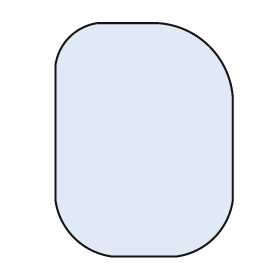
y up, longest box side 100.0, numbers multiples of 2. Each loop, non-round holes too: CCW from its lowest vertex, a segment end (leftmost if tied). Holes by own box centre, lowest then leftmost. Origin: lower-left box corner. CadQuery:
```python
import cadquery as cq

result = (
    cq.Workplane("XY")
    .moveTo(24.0, 0.0)
    .lineTo(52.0, 0.0)
    .threePointArc((68.0, 8.0), (76.0, 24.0))
    .lineTo(76.0, 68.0)
    .threePointArc((66.0, 90.0), (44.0, 100.0))
    .lineTo(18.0, 100.0)
    .threePointArc((6.0, 94.0), (0.0, 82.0))
    .lineTo(0.0, 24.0)
    .threePointArc((8.0, 8.0), (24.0, 0.0))
    .close()
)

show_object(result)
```